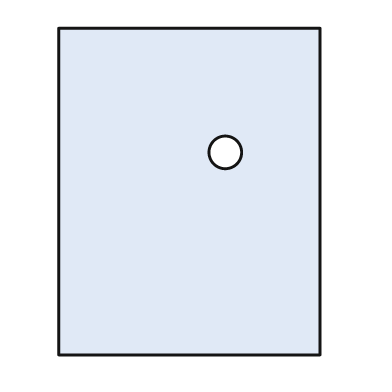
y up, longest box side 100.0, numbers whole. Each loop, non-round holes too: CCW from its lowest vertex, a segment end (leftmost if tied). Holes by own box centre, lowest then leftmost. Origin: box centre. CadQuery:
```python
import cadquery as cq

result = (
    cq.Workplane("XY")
    .moveTo(-40.0, -50.0)
    .lineTo(40.0, -50.0)
    .lineTo(40.0, 50.0)
    .lineTo(-40.0, 50.0)
    .close()
    .moveTo(11.0, 12.0)
    .circle(5.0)
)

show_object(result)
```